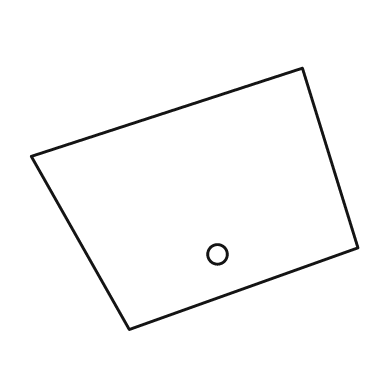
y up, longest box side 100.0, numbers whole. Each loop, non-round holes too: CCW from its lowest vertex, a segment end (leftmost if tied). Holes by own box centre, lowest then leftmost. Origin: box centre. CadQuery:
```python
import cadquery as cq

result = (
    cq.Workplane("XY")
    .moveTo(-20.0, -40.0)
    .lineTo(50.0, -15.0)
    .lineTo(33.0, 40.0)
    .lineTo(-50.0, 13.0)
    .close()
    .moveTo(7.0, -17.0)
    .circle(3.0)
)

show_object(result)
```